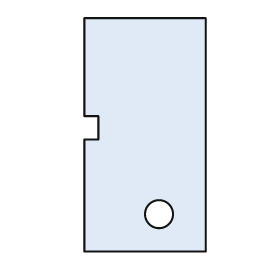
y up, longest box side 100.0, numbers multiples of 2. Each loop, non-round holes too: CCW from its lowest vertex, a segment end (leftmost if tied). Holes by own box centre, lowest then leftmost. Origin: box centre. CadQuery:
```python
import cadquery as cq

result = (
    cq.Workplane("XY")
    .moveTo(-26.0, -50.0)
    .lineTo(26.0, -50.0)
    .lineTo(26.0, 50.0)
    .lineTo(-26.0, 50.0)
    .lineTo(-26.0, 8.0)
    .lineTo(-20.0, 8.0)
    .lineTo(-20.0, -2.0)
    .lineTo(-26.0, -2.0)
    .close()
    .moveTo(6.0, -34.0)
    .circle(6.0)
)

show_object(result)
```